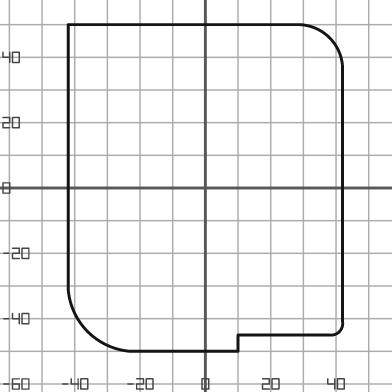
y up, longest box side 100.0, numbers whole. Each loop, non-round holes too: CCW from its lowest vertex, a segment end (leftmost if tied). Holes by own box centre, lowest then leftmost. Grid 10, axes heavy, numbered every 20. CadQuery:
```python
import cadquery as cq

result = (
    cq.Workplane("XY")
    .moveTo(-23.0, -50.0)
    .lineTo(10.0, -50.0)
    .lineTo(10.0, -45.0)
    .lineTo(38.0, -45.0)
    .threePointArc((41.0, -44.0), (42.0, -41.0))
    .lineTo(42.0, 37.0)
    .threePointArc((38.0, 46.0), (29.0, 50.0))
    .lineTo(-42.0, 50.0)
    .lineTo(-42.0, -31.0)
    .threePointArc((-36.0, -44.0), (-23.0, -50.0))
    .close()
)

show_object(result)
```